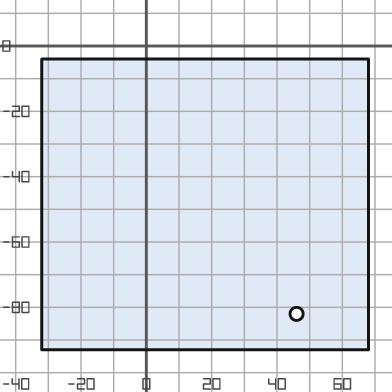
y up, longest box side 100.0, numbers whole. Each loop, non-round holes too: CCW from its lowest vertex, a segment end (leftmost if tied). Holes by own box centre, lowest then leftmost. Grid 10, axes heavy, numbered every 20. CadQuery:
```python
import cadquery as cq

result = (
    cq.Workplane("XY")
    .moveTo(-32.0, -93.0)
    .lineTo(68.0, -93.0)
    .lineTo(68.0, -4.0)
    .lineTo(-32.0, -4.0)
    .close()
    .moveTo(46.0, -82.0)
    .circle(2.0)
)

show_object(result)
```